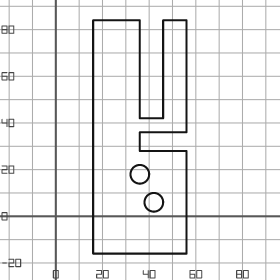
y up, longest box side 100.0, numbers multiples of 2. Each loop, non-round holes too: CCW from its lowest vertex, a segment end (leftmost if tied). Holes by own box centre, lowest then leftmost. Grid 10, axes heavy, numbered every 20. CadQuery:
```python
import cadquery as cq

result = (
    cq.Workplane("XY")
    .moveTo(16.0, -16.0)
    .lineTo(56.0, -16.0)
    .lineTo(56.0, 28.0)
    .lineTo(36.0, 28.0)
    .lineTo(36.0, 36.0)
    .lineTo(56.0, 36.0)
    .lineTo(56.0, 84.0)
    .lineTo(46.0, 84.0)
    .lineTo(46.0, 42.0)
    .lineTo(36.0, 42.0)
    .lineTo(36.0, 84.0)
    .lineTo(16.0, 84.0)
    .close()
    .moveTo(42.0, 6.0)
    .circle(4.0)
    .moveTo(36.0, 18.0)
    .circle(4.0)
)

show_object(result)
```